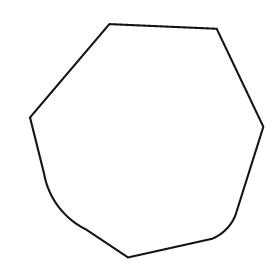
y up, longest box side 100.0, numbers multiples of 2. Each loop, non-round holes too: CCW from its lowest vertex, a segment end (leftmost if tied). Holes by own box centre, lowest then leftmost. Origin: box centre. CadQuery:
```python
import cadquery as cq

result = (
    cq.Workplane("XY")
    .moveTo(-8.0, -50.0)
    .lineTo(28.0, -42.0)
    .threePointArc((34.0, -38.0), (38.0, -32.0))
    .lineTo(50.0, 6.0)
    .lineTo(30.0, 48.0)
    .lineTo(-16.0, 50.0)
    .lineTo(-50.0, 10.0)
    .lineTo(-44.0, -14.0)
    .threePointArc((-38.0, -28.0), (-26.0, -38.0))
    .close()
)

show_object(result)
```